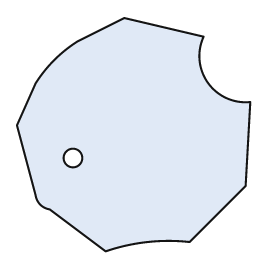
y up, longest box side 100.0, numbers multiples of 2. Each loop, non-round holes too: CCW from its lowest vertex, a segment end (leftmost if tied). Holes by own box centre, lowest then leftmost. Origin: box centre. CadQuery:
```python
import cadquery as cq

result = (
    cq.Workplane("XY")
    .moveTo(-12.0, -50.0)
    .threePointArc((6.0, -46.0), (24.0, -46.0))
    .lineTo(48.0, -22.0)
    .lineTo(50.0, 14.0)
    .threePointArc((32.0, 22.0), (30.0, 42.0))
    .lineTo(-4.0, 50.0)
    .lineTo(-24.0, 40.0)
    .threePointArc((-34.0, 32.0), (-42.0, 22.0))
    .lineTo(-50.0, 4.0)
    .lineTo(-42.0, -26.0)
    .threePointArc((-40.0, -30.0), (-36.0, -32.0))
    .close()
    .moveTo(-26.0, -10.0)
    .circle(4.0)
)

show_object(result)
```